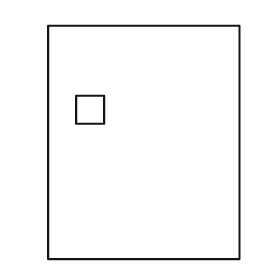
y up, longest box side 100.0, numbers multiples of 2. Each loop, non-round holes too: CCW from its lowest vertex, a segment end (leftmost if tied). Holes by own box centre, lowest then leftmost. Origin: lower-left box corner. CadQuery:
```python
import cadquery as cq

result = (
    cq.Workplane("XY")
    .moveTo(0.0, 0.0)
    .lineTo(82.0, 0.0)
    .lineTo(82.0, 100.0)
    .lineTo(0.0, 100.0)
    .close()
    .moveTo(12.0, 58.0)
    .lineTo(24.0, 58.0)
    .lineTo(24.0, 70.0)
    .lineTo(12.0, 70.0)
    .close()
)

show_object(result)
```